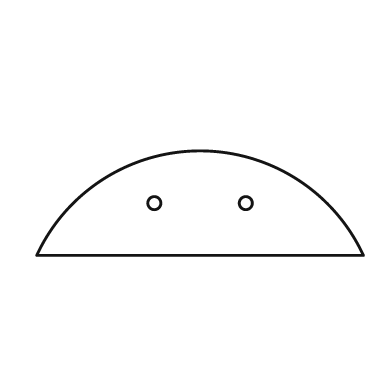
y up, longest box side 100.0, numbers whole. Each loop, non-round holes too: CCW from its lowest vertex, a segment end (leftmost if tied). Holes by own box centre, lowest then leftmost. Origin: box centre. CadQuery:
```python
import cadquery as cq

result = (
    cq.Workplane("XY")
    .moveTo(-50.0, -16.0)
    .lineTo(50.0, -16.0)
    .threePointArc((0.0, 16.0), (-50.0, -16.0))
    .close()
    .moveTo(-14.0, 0.0)
    .circle(2.0)
    .moveTo(14.0, 0.0)
    .circle(2.0)
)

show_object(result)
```